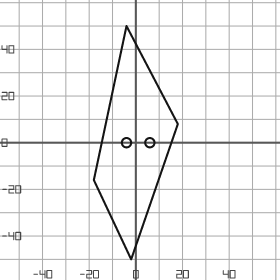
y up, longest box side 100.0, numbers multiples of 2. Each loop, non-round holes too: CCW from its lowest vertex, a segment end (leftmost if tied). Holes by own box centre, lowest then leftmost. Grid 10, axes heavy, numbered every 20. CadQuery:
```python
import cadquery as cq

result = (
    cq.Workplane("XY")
    .moveTo(-2.0, -50.0)
    .lineTo(18.0, 8.0)
    .lineTo(-4.0, 50.0)
    .lineTo(-18.0, -16.0)
    .close()
    .moveTo(-4.0, 0.0)
    .circle(2.0)
    .moveTo(6.0, 0.0)
    .circle(2.0)
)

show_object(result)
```